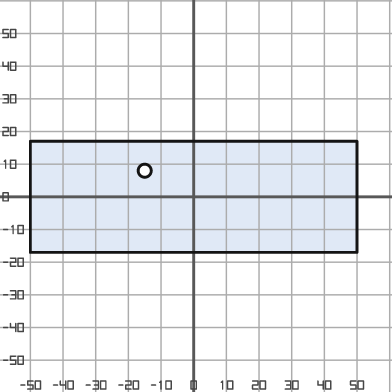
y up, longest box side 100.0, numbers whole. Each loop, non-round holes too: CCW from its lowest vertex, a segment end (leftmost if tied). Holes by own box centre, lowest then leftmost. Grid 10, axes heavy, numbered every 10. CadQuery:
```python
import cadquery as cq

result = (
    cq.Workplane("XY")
    .moveTo(-50.0, -17.0)
    .lineTo(50.0, -17.0)
    .lineTo(50.0, 17.0)
    .lineTo(-50.0, 17.0)
    .close()
    .moveTo(-15.0, 8.0)
    .circle(2.0)
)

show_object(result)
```